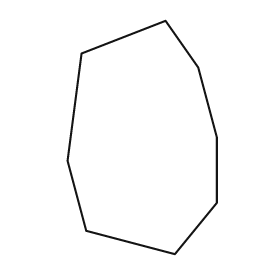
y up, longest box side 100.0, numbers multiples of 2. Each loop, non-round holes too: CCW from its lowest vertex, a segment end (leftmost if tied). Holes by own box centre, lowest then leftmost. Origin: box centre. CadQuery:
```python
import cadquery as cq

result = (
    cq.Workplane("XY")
    .moveTo(14.0, -50.0)
    .lineTo(32.0, -28.0)
    .lineTo(32.0, 0.0)
    .lineTo(24.0, 30.0)
    .lineTo(10.0, 50.0)
    .lineTo(-26.0, 36.0)
    .lineTo(-32.0, -10.0)
    .lineTo(-24.0, -40.0)
    .close()
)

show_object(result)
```